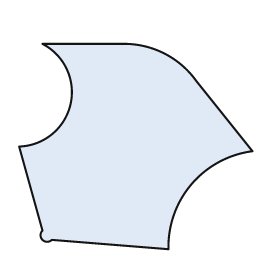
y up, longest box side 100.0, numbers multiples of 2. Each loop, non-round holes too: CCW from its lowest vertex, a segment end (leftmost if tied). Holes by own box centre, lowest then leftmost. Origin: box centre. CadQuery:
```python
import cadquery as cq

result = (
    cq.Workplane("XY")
    .moveTo(14.0, -44.0)
    .threePointArc((24.0, -16.0), (50.0, -2.0))
    .lineTo(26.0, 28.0)
    .threePointArc((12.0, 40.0), (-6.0, 44.0))
    .lineTo(-40.0, 44.0)
    .threePointArc((-28.0, 18.0), (-50.0, 0.0))
    .lineTo(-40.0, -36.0)
    .threePointArc((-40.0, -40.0), (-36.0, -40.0))
    .close()
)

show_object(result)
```